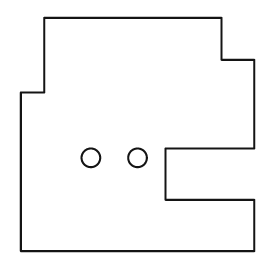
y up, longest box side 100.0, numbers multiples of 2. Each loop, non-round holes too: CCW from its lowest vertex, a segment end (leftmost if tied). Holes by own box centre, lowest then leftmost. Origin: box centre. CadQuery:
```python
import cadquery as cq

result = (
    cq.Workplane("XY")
    .moveTo(-50.0, -50.0)
    .lineTo(50.0, -50.0)
    .lineTo(50.0, -28.0)
    .lineTo(12.0, -28.0)
    .lineTo(12.0, -6.0)
    .lineTo(50.0, -6.0)
    .lineTo(50.0, 32.0)
    .lineTo(36.0, 32.0)
    .lineTo(36.0, 50.0)
    .lineTo(-40.0, 50.0)
    .lineTo(-40.0, 18.0)
    .lineTo(-50.0, 18.0)
    .close()
    .moveTo(-20.0, -10.0)
    .circle(4.0)
    .moveTo(0.0, -10.0)
    .circle(4.0)
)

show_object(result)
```